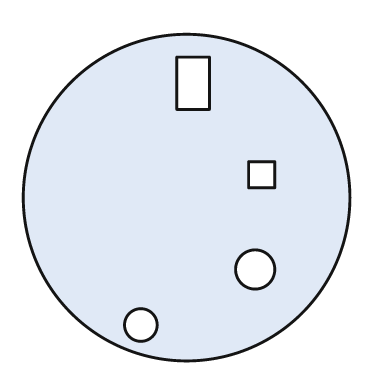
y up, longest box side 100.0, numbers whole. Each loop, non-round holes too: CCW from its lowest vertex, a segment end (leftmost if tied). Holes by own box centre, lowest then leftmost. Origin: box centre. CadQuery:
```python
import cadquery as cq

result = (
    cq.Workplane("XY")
    .moveTo(0.0, 0.0)
    .circle(50.0)
    .moveTo(-14.0, -39.0)
    .circle(5.0)
    .moveTo(21.0, -22.0)
    .circle(6.0)
    .moveTo(19.0, 3.0)
    .lineTo(27.0, 3.0)
    .lineTo(27.0, 11.0)
    .lineTo(19.0, 11.0)
    .close()
    .moveTo(-3.0, 27.0)
    .lineTo(7.0, 27.0)
    .lineTo(7.0, 43.0)
    .lineTo(-3.0, 43.0)
    .close()
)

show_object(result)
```